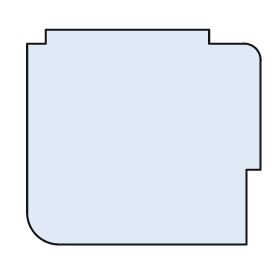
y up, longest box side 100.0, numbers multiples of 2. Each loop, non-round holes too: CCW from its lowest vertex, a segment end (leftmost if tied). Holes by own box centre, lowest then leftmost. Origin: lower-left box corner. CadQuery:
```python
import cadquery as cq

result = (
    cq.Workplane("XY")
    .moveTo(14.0, 0.0)
    .lineTo(94.0, 0.0)
    .lineTo(94.0, 32.0)
    .lineTo(100.0, 32.0)
    .lineTo(100.0, 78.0)
    .threePointArc((98.0, 84.0), (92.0, 86.0))
    .lineTo(78.0, 86.0)
    .lineTo(78.0, 92.0)
    .lineTo(8.0, 92.0)
    .lineTo(8.0, 86.0)
    .lineTo(0.0, 86.0)
    .lineTo(0.0, 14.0)
    .threePointArc((4.0, 4.0), (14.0, 0.0))
    .close()
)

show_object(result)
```